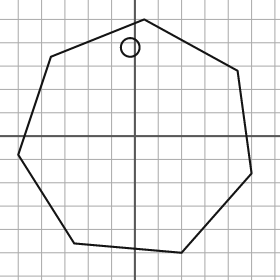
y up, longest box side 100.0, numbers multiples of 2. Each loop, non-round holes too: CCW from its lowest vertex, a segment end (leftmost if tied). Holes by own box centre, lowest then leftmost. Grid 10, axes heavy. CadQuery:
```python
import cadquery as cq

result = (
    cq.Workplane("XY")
    .moveTo(20.0, -50.0)
    .lineTo(50.0, -16.0)
    .lineTo(44.0, 28.0)
    .lineTo(4.0, 50.0)
    .lineTo(-36.0, 34.0)
    .lineTo(-50.0, -8.0)
    .lineTo(-26.0, -46.0)
    .close()
    .moveTo(-2.0, 38.0)
    .circle(4.0)
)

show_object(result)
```